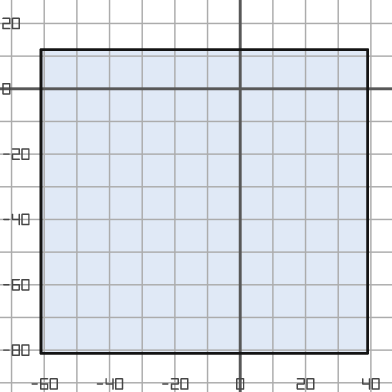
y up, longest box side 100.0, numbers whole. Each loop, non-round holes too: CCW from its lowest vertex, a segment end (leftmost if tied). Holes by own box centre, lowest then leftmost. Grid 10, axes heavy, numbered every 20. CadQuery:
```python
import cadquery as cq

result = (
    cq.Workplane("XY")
    .moveTo(-61.0, -81.0)
    .lineTo(39.0, -81.0)
    .lineTo(39.0, 12.0)
    .lineTo(-61.0, 12.0)
    .close()
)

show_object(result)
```